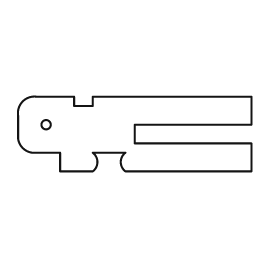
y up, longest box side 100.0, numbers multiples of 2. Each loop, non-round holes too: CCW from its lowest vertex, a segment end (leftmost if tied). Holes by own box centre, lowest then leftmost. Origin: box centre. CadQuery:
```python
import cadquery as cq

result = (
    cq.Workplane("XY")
    .moveTo(-32.0, -16.0)
    .lineTo(-18.0, -16.0)
    .threePointArc((-16.0, -12.0), (-18.0, -8.0))
    .lineTo(-4.0, -8.0)
    .threePointArc((-6.0, -12.0), (-4.0, -16.0))
    .lineTo(50.0, -16.0)
    .lineTo(50.0, -4.0)
    .lineTo(0.0, -4.0)
    .lineTo(0.0, 4.0)
    .lineTo(50.0, 4.0)
    .lineTo(50.0, 16.0)
    .lineTo(-18.0, 16.0)
    .lineTo(-18.0, 12.0)
    .lineTo(-26.0, 12.0)
    .lineTo(-26.0, 16.0)
    .lineTo(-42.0, 16.0)
    .threePointArc((-48.0, 14.0), (-50.0, 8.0))
    .lineTo(-50.0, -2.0)
    .threePointArc((-48.0, -6.0), (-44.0, -8.0))
    .lineTo(-32.0, -8.0)
    .close()
    .moveTo(-38.0, 4.0)
    .circle(2.0)
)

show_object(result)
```